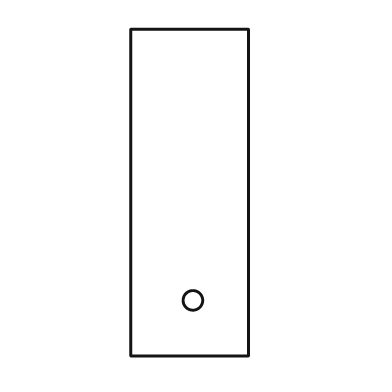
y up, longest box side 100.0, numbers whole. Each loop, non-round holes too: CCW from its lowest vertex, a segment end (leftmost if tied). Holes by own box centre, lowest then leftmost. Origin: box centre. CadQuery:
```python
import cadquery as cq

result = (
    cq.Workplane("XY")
    .moveTo(-18.0, -50.0)
    .lineTo(18.0, -50.0)
    .lineTo(18.0, 50.0)
    .lineTo(-18.0, 50.0)
    .close()
    .moveTo(1.0, -33.0)
    .circle(3.0)
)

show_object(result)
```